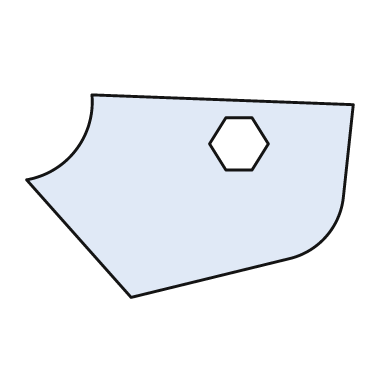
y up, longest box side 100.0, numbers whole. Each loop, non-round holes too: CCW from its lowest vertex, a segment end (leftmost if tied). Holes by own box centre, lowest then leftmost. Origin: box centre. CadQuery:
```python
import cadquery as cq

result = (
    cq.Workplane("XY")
    .moveTo(-18.0, -31.0)
    .lineTo(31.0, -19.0)
    .threePointArc((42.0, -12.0), (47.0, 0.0))
    .lineTo(50.0, 28.0)
    .lineTo(-30.0, 31.0)
    .threePointArc((-35.0, 14.0), (-50.0, 5.0))
    .close()
    .moveTo(11.0, 8.0)
    .lineTo(19.0, 8.0)
    .lineTo(24.0, 16.0)
    .lineTo(19.0, 24.0)
    .lineTo(11.0, 24.0)
    .lineTo(6.0, 16.0)
    .close()
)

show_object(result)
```